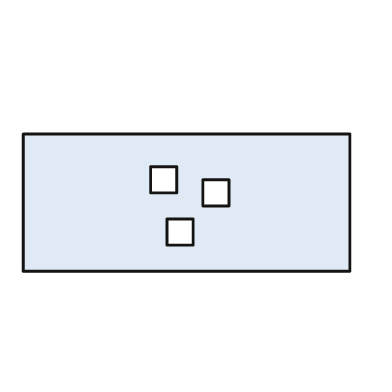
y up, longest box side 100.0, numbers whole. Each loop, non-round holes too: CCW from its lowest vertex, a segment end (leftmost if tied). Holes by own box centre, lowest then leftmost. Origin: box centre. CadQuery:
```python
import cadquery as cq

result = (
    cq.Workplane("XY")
    .moveTo(-50.0, -21.0)
    .lineTo(50.0, -21.0)
    .lineTo(50.0, 21.0)
    .lineTo(-50.0, 21.0)
    .close()
    .moveTo(-6.0, -13.0)
    .lineTo(2.0, -13.0)
    .lineTo(2.0, -5.0)
    .lineTo(-6.0, -5.0)
    .close()
    .moveTo(5.0, -1.0)
    .lineTo(13.0, -1.0)
    .lineTo(13.0, 7.0)
    .lineTo(5.0, 7.0)
    .close()
    .moveTo(-11.0, 3.0)
    .lineTo(-3.0, 3.0)
    .lineTo(-3.0, 11.0)
    .lineTo(-11.0, 11.0)
    .close()
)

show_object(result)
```